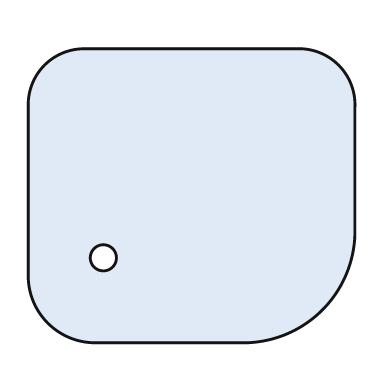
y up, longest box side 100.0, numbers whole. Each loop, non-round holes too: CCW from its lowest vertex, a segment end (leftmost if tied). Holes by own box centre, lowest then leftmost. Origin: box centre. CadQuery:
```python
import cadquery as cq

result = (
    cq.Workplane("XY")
    .moveTo(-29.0, -45.0)
    .lineTo(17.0, -45.0)
    .threePointArc((40.0, -35.0), (50.0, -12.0))
    .lineTo(50.0, 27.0)
    .threePointArc((45.0, 40.0), (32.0, 45.0))
    .lineTo(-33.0, 45.0)
    .threePointArc((-45.0, 40.0), (-50.0, 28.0))
    .lineTo(-50.0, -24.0)
    .threePointArc((-44.0, -39.0), (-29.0, -45.0))
    .close()
    .moveTo(-27.0, -19.0)
    .circle(4.0)
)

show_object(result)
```